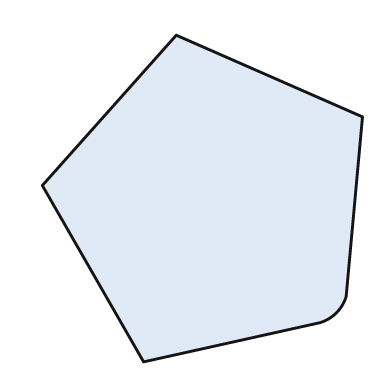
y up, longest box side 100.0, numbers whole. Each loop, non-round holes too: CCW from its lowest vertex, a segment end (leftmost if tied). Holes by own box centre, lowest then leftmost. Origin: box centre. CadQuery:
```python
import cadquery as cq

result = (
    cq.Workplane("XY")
    .moveTo(-18.0, -50.0)
    .lineTo(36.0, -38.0)
    .threePointArc((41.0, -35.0), (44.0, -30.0))
    .lineTo(49.0, 25.0)
    .lineTo(-8.0, 50.0)
    .lineTo(-49.0, 4.0)
    .close()
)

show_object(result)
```